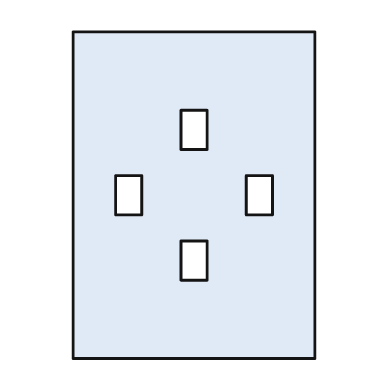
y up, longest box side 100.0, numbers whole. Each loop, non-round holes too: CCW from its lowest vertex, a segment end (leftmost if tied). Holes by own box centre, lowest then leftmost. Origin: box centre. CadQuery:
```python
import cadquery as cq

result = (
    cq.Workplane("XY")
    .moveTo(-37.0, -50.0)
    .lineTo(37.0, -50.0)
    .lineTo(37.0, 50.0)
    .lineTo(-37.0, 50.0)
    .close()
    .moveTo(-4.0, -26.0)
    .lineTo(4.0, -26.0)
    .lineTo(4.0, -14.0)
    .lineTo(-4.0, -14.0)
    .close()
    .moveTo(-24.0, -6.0)
    .lineTo(-16.0, -6.0)
    .lineTo(-16.0, 6.0)
    .lineTo(-24.0, 6.0)
    .close()
    .moveTo(16.0, -6.0)
    .lineTo(24.0, -6.0)
    .lineTo(24.0, 6.0)
    .lineTo(16.0, 6.0)
    .close()
    .moveTo(-4.0, 14.0)
    .lineTo(4.0, 14.0)
    .lineTo(4.0, 26.0)
    .lineTo(-4.0, 26.0)
    .close()
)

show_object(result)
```